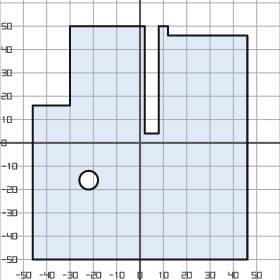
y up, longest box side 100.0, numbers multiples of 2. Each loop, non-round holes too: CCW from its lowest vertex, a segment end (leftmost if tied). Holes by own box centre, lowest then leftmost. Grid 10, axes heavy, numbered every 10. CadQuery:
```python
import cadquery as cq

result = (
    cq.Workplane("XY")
    .moveTo(-46.0, -50.0)
    .lineTo(46.0, -50.0)
    .lineTo(46.0, 46.0)
    .lineTo(12.0, 46.0)
    .lineTo(12.0, 50.0)
    .lineTo(8.0, 50.0)
    .lineTo(8.0, 4.0)
    .lineTo(2.0, 4.0)
    .lineTo(2.0, 50.0)
    .lineTo(-30.0, 50.0)
    .lineTo(-30.0, 16.0)
    .lineTo(-46.0, 16.0)
    .close()
    .moveTo(-22.0, -16.0)
    .circle(4.0)
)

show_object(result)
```